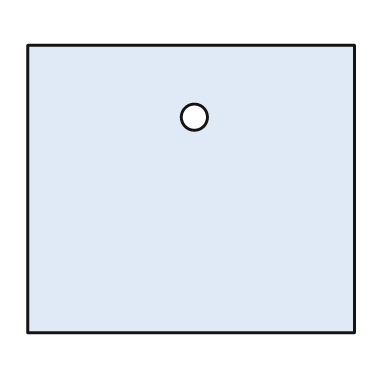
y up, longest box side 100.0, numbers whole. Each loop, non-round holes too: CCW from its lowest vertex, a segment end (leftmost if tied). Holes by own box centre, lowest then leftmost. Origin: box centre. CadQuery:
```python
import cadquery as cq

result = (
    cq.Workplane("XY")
    .moveTo(-50.0, -44.0)
    .lineTo(50.0, -44.0)
    .lineTo(50.0, 44.0)
    .lineTo(-50.0, 44.0)
    .close()
    .moveTo(1.0, 22.0)
    .circle(4.0)
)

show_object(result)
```